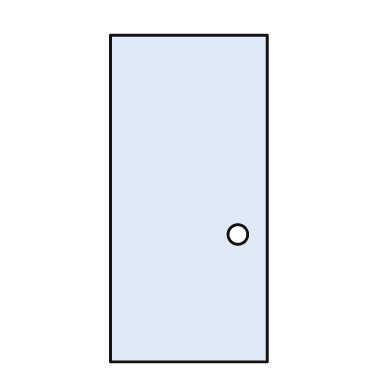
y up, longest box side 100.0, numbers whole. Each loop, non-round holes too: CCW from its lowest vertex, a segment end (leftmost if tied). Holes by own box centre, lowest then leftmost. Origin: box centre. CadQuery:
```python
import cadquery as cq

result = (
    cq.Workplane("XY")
    .moveTo(-24.0, -50.0)
    .lineTo(24.0, -50.0)
    .lineTo(24.0, 50.0)
    .lineTo(-24.0, 50.0)
    .close()
    .moveTo(15.0, -11.0)
    .circle(3.0)
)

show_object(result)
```